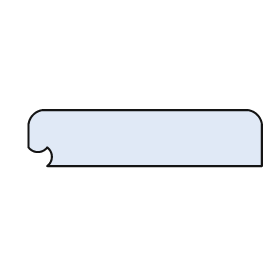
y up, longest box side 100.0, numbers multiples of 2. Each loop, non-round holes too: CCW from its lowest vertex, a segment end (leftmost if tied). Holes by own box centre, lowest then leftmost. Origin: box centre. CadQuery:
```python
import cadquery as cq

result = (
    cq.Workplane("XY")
    .moveTo(-42.0, -12.0)
    .lineTo(50.0, -12.0)
    .lineTo(50.0, 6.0)
    .threePointArc((48.0, 10.0), (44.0, 12.0))
    .lineTo(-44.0, 12.0)
    .threePointArc((-48.0, 10.0), (-50.0, 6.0))
    .lineTo(-50.0, -4.0)
    .threePointArc((-46.0, -6.0), (-42.0, -4.0))
    .threePointArc((-40.0, -8.0), (-42.0, -12.0))
    .close()
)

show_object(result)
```